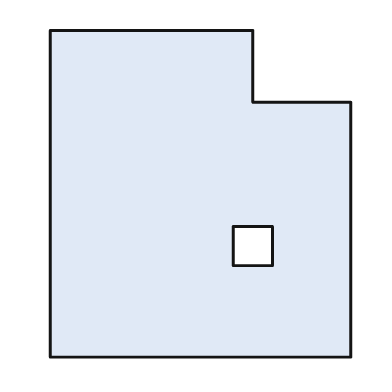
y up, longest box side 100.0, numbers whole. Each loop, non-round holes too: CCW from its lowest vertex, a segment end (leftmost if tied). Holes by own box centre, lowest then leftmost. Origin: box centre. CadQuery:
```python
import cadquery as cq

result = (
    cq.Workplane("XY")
    .moveTo(-46.0, -50.0)
    .lineTo(46.0, -50.0)
    .lineTo(46.0, 28.0)
    .lineTo(16.0, 28.0)
    .lineTo(16.0, 50.0)
    .lineTo(-46.0, 50.0)
    .close()
    .moveTo(10.0, -22.0)
    .lineTo(22.0, -22.0)
    .lineTo(22.0, -10.0)
    .lineTo(10.0, -10.0)
    .close()
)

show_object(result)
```